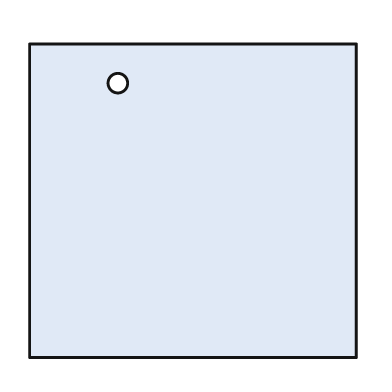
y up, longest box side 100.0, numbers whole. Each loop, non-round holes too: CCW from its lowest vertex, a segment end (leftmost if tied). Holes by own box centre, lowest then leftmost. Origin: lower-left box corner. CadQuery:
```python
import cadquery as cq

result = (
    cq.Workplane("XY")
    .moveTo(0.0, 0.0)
    .lineTo(100.0, 0.0)
    .lineTo(100.0, 96.0)
    .lineTo(0.0, 96.0)
    .close()
    .moveTo(27.0, 84.0)
    .circle(3.0)
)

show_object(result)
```